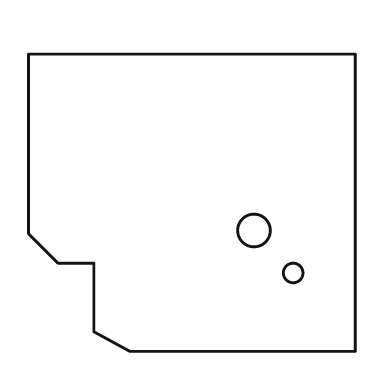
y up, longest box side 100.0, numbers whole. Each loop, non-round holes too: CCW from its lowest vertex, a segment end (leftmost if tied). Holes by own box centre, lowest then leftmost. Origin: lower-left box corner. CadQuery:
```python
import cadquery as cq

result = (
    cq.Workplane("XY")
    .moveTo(31.0, 0.0)
    .lineTo(100.0, 0.0)
    .lineTo(100.0, 91.0)
    .lineTo(0.0, 91.0)
    .lineTo(0.0, 36.0)
    .lineTo(9.0, 27.0)
    .lineTo(20.0, 27.0)
    .lineTo(20.0, 6.0)
    .close()
    .moveTo(81.0, 24.0)
    .circle(3.0)
    .moveTo(69.0, 37.0)
    .circle(5.0)
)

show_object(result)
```